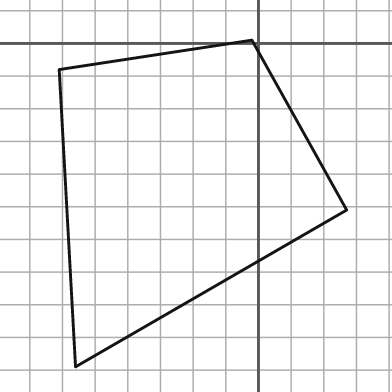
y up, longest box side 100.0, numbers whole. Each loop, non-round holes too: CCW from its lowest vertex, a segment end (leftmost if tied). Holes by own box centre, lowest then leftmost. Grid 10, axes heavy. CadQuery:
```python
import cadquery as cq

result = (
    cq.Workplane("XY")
    .moveTo(-56.0, -99.0)
    .lineTo(27.0, -51.0)
    .lineTo(-2.0, 1.0)
    .lineTo(-61.0, -8.0)
    .close()
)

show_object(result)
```